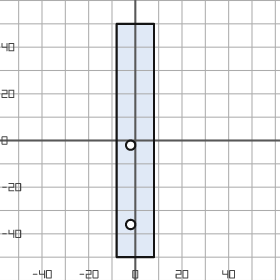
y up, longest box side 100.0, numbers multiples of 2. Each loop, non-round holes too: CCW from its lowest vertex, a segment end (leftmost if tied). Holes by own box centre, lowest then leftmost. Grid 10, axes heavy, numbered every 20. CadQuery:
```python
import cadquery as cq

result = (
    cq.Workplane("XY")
    .moveTo(-8.0, -50.0)
    .lineTo(8.0, -50.0)
    .lineTo(8.0, 50.0)
    .lineTo(-8.0, 50.0)
    .close()
    .moveTo(-2.0, -36.0)
    .circle(2.0)
    .moveTo(-2.0, -2.0)
    .circle(2.0)
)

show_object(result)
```